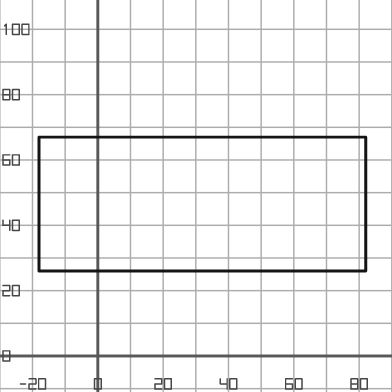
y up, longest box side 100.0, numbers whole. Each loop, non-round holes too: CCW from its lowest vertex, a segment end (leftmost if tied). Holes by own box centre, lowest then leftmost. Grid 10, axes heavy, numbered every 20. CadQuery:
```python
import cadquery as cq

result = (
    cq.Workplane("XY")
    .moveTo(-18.0, 26.0)
    .lineTo(82.0, 26.0)
    .lineTo(82.0, 67.0)
    .lineTo(-18.0, 67.0)
    .close()
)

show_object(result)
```